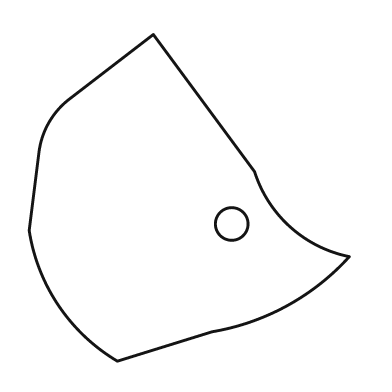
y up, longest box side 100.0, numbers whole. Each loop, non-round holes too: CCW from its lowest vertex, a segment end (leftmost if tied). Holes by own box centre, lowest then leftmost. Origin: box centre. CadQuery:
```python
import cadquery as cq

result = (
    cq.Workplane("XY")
    .moveTo(-22.0, -50.0)
    .lineTo(7.0, -41.0)
    .threePointArc((30.0, -33.0), (49.0, -18.0))
    .threePointArc((31.0, -9.0), (20.0, 8.0))
    .lineTo(-11.0, 50.0)
    .lineTo(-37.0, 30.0)
    .threePointArc((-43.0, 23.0), (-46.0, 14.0))
    .lineTo(-49.0, -10.0)
    .threePointArc((-40.0, -33.0), (-22.0, -50.0))
    .close()
    .moveTo(13.0, -8.0)
    .circle(5.0)
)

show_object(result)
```